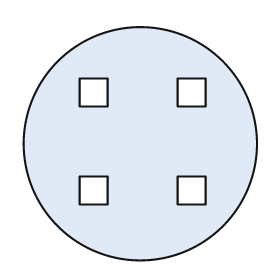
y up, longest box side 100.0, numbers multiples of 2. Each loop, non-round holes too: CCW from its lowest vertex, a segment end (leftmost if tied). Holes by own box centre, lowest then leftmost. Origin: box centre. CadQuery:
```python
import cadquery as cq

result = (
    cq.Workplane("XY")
    .moveTo(0.0, 0.0)
    .circle(50.0)
    .moveTo(-26.0, -26.0)
    .lineTo(-14.0, -26.0)
    .lineTo(-14.0, -14.0)
    .lineTo(-26.0, -14.0)
    .close()
    .moveTo(16.0, -26.0)
    .lineTo(28.0, -26.0)
    .lineTo(28.0, -14.0)
    .lineTo(16.0, -14.0)
    .close()
    .moveTo(-26.0, 16.0)
    .lineTo(-14.0, 16.0)
    .lineTo(-14.0, 28.0)
    .lineTo(-26.0, 28.0)
    .close()
    .moveTo(16.0, 16.0)
    .lineTo(28.0, 16.0)
    .lineTo(28.0, 28.0)
    .lineTo(16.0, 28.0)
    .close()
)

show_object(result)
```